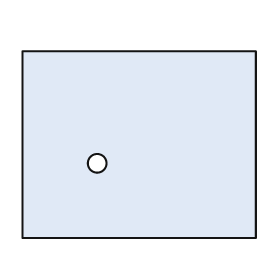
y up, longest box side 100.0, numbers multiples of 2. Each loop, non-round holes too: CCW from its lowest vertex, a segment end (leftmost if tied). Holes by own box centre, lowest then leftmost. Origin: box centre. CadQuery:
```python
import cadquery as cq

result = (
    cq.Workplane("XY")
    .moveTo(-50.0, -40.0)
    .lineTo(50.0, -40.0)
    .lineTo(50.0, 40.0)
    .lineTo(-50.0, 40.0)
    .close()
    .moveTo(-18.0, -8.0)
    .circle(4.0)
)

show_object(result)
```